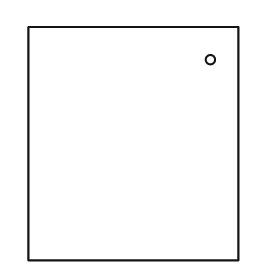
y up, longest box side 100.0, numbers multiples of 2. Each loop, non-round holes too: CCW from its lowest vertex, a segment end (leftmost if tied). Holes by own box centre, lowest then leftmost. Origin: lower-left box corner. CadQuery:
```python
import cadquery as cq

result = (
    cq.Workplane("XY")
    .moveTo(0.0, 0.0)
    .lineTo(90.0, 0.0)
    .lineTo(90.0, 100.0)
    .lineTo(0.0, 100.0)
    .close()
    .moveTo(78.0, 86.0)
    .circle(2.0)
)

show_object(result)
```